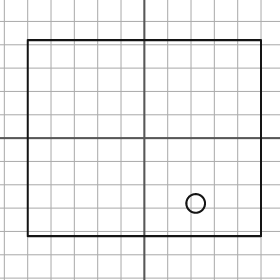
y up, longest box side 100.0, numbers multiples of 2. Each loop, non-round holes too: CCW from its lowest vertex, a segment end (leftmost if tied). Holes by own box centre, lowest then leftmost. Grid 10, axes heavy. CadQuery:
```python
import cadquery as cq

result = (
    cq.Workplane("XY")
    .moveTo(-50.0, -42.0)
    .lineTo(50.0, -42.0)
    .lineTo(50.0, 42.0)
    .lineTo(-50.0, 42.0)
    .close()
    .moveTo(22.0, -28.0)
    .circle(4.0)
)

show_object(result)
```